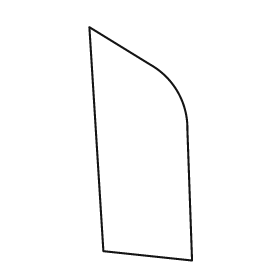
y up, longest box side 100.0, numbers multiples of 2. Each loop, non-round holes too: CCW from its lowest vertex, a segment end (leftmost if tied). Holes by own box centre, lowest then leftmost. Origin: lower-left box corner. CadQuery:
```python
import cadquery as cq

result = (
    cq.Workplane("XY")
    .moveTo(44.0, 0.0)
    .lineTo(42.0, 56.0)
    .threePointArc((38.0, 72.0), (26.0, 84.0))
    .lineTo(0.0, 100.0)
    .lineTo(6.0, 4.0)
    .close()
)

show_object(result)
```